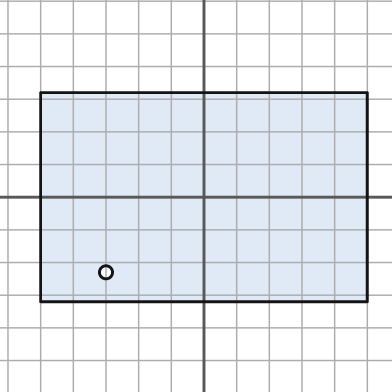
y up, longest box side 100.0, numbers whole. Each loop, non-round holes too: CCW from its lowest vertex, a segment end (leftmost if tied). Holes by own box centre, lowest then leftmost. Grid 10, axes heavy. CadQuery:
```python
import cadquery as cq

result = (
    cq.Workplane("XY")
    .moveTo(-50.0, -32.0)
    .lineTo(50.0, -32.0)
    .lineTo(50.0, 32.0)
    .lineTo(-50.0, 32.0)
    .close()
    .moveTo(-30.0, -23.0)
    .circle(2.0)
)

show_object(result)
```